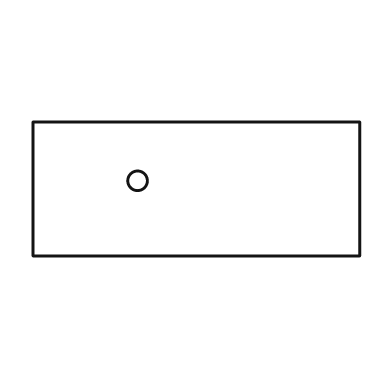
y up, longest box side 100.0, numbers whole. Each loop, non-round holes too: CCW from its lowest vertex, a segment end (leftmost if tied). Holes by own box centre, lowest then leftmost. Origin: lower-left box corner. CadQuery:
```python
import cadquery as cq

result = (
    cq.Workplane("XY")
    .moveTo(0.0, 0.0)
    .lineTo(100.0, 0.0)
    .lineTo(100.0, 41.0)
    .lineTo(0.0, 41.0)
    .close()
    .moveTo(32.0, 23.0)
    .circle(3.0)
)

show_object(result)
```